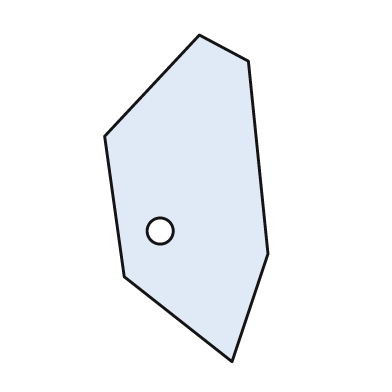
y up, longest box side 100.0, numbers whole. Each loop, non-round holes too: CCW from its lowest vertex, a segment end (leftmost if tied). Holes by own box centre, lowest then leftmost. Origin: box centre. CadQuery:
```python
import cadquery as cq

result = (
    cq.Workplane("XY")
    .moveTo(14.0, -50.0)
    .lineTo(25.0, -17.0)
    .lineTo(19.0, 42.0)
    .lineTo(4.0, 50.0)
    .lineTo(-25.0, 19.0)
    .lineTo(-19.0, -24.0)
    .close()
    .moveTo(-8.0, -10.0)
    .circle(4.0)
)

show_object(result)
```